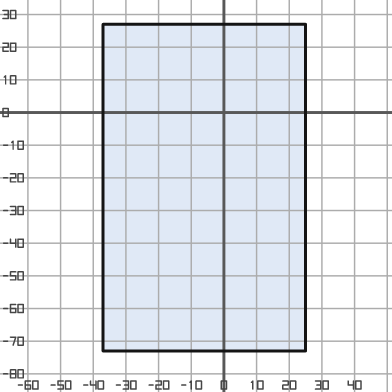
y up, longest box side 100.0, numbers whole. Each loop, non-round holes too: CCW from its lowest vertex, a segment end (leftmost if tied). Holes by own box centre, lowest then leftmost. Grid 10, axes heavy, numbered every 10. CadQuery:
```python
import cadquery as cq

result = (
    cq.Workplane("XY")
    .moveTo(-37.0, -73.0)
    .lineTo(25.0, -73.0)
    .lineTo(25.0, 27.0)
    .lineTo(-37.0, 27.0)
    .close()
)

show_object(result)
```